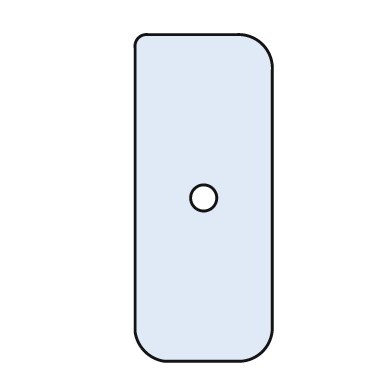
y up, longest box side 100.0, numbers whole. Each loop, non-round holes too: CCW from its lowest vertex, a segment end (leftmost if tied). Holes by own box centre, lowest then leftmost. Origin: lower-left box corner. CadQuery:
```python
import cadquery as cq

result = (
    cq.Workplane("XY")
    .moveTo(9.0, 0.0)
    .lineTo(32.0, 0.0)
    .threePointArc((39.0, 3.0), (42.0, 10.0))
    .lineTo(42.0, 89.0)
    .threePointArc((39.0, 97.0), (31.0, 100.0))
    .lineTo(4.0, 100.0)
    .threePointArc((1.0, 99.0), (0.0, 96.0))
    .lineTo(0.0, 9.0)
    .threePointArc((3.0, 3.0), (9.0, 0.0))
    .close()
    .moveTo(21.0, 50.0)
    .circle(4.0)
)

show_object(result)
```